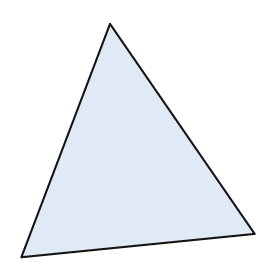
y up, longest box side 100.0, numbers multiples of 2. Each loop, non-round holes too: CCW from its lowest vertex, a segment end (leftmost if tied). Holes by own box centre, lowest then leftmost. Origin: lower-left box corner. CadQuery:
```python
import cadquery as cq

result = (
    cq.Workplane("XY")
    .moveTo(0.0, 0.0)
    .lineTo(100.0, 10.0)
    .lineTo(38.0, 100.0)
    .close()
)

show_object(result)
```